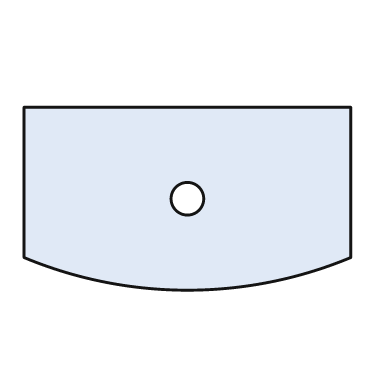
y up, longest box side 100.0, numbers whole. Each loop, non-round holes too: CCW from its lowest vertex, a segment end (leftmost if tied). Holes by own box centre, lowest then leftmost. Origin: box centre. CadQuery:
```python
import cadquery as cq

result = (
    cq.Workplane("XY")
    .moveTo(-50.0, -18.0)
    .threePointArc((0.0, -28.0), (50.0, -18.0))
    .lineTo(50.0, 28.0)
    .lineTo(-50.0, 28.0)
    .close()
    .moveTo(0.0, 0.0)
    .circle(5.0)
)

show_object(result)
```